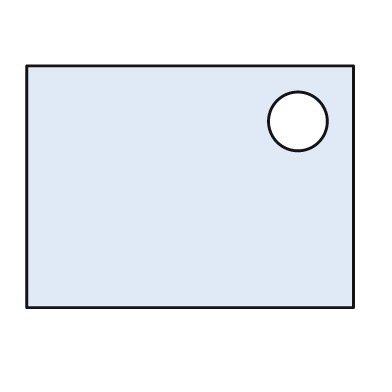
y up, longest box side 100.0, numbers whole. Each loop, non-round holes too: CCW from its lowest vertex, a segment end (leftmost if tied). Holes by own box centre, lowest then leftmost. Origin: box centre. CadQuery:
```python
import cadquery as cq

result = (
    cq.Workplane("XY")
    .moveTo(-50.0, -37.0)
    .lineTo(50.0, -37.0)
    .lineTo(50.0, 37.0)
    .lineTo(-50.0, 37.0)
    .close()
    .moveTo(33.0, 20.0)
    .circle(9.0)
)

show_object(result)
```